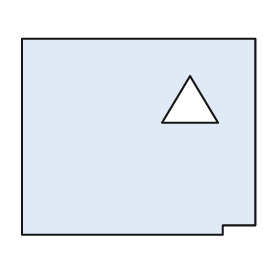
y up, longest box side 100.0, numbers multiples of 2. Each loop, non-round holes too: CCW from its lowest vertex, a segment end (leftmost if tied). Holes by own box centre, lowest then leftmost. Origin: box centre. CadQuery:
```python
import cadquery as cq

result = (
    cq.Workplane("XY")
    .moveTo(-50.0, -42.0)
    .lineTo(36.0, -42.0)
    .lineTo(36.0, -38.0)
    .lineTo(50.0, -38.0)
    .lineTo(50.0, 42.0)
    .lineTo(-50.0, 42.0)
    .close()
    .moveTo(10.0, 6.0)
    .lineTo(34.0, 6.0)
    .lineTo(22.0, 26.0)
    .close()
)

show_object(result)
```